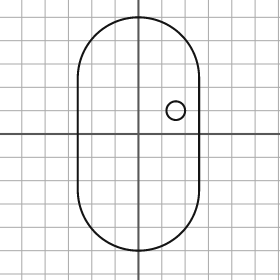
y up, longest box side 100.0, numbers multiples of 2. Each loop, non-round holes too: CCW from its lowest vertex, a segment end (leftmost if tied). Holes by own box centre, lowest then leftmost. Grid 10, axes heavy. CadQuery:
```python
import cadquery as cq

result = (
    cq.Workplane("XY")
    .moveTo(-26.0, -24.0)
    .threePointArc((0.0, -50.0), (26.0, -24.0))
    .lineTo(26.0, 24.0)
    .threePointArc((0.0, 50.0), (-26.0, 24.0))
    .close()
    .moveTo(16.0, 10.0)
    .circle(4.0)
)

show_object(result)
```